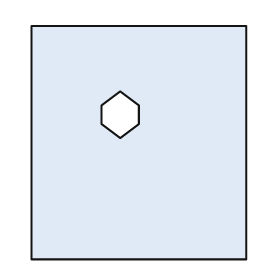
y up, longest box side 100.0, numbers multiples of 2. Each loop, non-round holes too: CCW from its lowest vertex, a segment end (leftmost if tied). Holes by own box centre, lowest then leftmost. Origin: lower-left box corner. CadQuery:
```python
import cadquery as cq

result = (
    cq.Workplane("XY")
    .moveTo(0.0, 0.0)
    .lineTo(92.0, 0.0)
    .lineTo(92.0, 100.0)
    .lineTo(0.0, 100.0)
    .close()
    .moveTo(38.0, 52.0)
    .lineTo(46.0, 58.0)
    .lineTo(46.0, 66.0)
    .lineTo(38.0, 72.0)
    .lineTo(30.0, 66.0)
    .lineTo(30.0, 58.0)
    .close()
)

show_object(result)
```